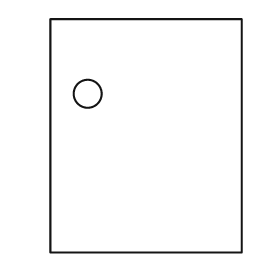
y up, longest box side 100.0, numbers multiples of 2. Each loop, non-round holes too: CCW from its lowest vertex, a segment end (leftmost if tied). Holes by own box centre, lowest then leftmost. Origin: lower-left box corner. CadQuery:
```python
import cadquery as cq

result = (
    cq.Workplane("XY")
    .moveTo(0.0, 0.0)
    .lineTo(82.0, 0.0)
    .lineTo(82.0, 100.0)
    .lineTo(0.0, 100.0)
    .close()
    .moveTo(16.0, 68.0)
    .circle(6.0)
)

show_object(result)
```